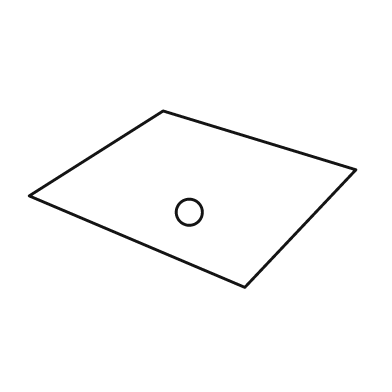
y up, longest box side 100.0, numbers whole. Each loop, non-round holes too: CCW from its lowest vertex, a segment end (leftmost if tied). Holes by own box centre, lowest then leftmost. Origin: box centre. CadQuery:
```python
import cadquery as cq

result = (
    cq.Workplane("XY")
    .moveTo(16.0, -27.0)
    .lineTo(50.0, 9.0)
    .lineTo(-9.0, 27.0)
    .lineTo(-50.0, 1.0)
    .close()
    .moveTo(-1.0, -4.0)
    .circle(4.0)
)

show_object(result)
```